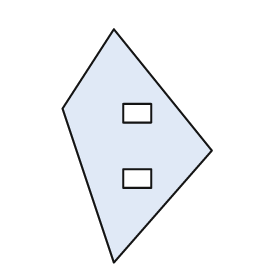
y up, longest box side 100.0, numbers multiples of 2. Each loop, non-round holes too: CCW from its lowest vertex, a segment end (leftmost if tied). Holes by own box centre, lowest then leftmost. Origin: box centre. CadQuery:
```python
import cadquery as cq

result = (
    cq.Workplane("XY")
    .moveTo(-10.0, -50.0)
    .lineTo(32.0, -2.0)
    .lineTo(-10.0, 50.0)
    .lineTo(-32.0, 16.0)
    .close()
    .moveTo(-6.0, -18.0)
    .lineTo(6.0, -18.0)
    .lineTo(6.0, -10.0)
    .lineTo(-6.0, -10.0)
    .close()
    .moveTo(-6.0, 10.0)
    .lineTo(6.0, 10.0)
    .lineTo(6.0, 18.0)
    .lineTo(-6.0, 18.0)
    .close()
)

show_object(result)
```